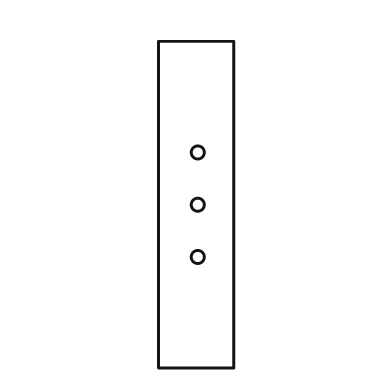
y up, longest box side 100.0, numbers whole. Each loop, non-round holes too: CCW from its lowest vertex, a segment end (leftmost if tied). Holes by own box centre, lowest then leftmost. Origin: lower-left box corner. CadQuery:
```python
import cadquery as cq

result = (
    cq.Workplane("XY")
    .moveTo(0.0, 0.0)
    .lineTo(23.0, 0.0)
    .lineTo(23.0, 100.0)
    .lineTo(0.0, 100.0)
    .close()
    .moveTo(12.0, 34.0)
    .circle(2.0)
    .moveTo(12.0, 50.0)
    .circle(2.0)
    .moveTo(12.0, 66.0)
    .circle(2.0)
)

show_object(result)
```